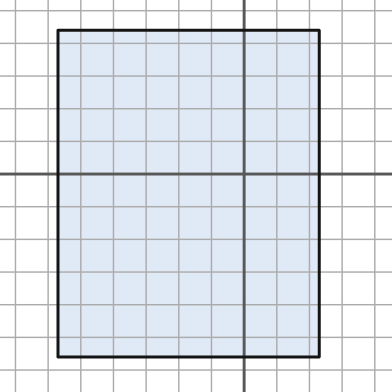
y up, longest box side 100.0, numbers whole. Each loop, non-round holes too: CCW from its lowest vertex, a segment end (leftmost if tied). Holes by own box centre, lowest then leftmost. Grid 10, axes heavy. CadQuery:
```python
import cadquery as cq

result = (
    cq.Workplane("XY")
    .moveTo(-57.0, -56.0)
    .lineTo(23.0, -56.0)
    .lineTo(23.0, 44.0)
    .lineTo(-57.0, 44.0)
    .close()
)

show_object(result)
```